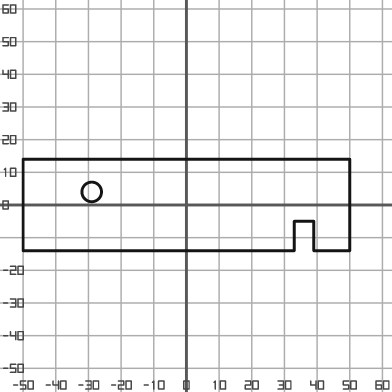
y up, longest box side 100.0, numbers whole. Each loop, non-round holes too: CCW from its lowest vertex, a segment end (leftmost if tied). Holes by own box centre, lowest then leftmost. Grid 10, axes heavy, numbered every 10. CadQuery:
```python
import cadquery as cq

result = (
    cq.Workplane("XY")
    .moveTo(-50.0, -14.0)
    .lineTo(33.0, -14.0)
    .lineTo(33.0, -5.0)
    .lineTo(39.0, -5.0)
    .lineTo(39.0, -14.0)
    .lineTo(50.0, -14.0)
    .lineTo(50.0, 14.0)
    .lineTo(-50.0, 14.0)
    .close()
    .moveTo(-29.0, 4.0)
    .circle(3.0)
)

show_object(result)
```